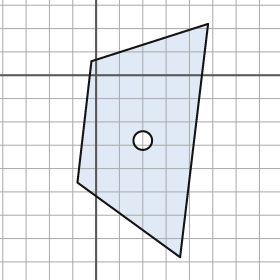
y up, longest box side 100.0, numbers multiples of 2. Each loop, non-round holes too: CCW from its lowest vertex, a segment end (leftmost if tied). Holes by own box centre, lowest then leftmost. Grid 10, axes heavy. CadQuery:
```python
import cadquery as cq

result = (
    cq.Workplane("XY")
    .moveTo(36.0, -78.0)
    .lineTo(48.0, 22.0)
    .lineTo(-2.0, 6.0)
    .lineTo(-8.0, -46.0)
    .close()
    .moveTo(20.0, -28.0)
    .circle(4.0)
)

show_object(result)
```